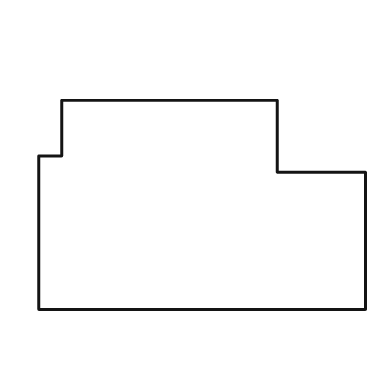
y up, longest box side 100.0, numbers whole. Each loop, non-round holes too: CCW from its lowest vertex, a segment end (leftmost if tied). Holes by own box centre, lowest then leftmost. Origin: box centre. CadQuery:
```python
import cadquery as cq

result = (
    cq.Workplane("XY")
    .moveTo(-50.0, -32.0)
    .lineTo(50.0, -32.0)
    .lineTo(50.0, 10.0)
    .lineTo(23.0, 10.0)
    .lineTo(23.0, 32.0)
    .lineTo(-43.0, 32.0)
    .lineTo(-43.0, 15.0)
    .lineTo(-50.0, 15.0)
    .close()
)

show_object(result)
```